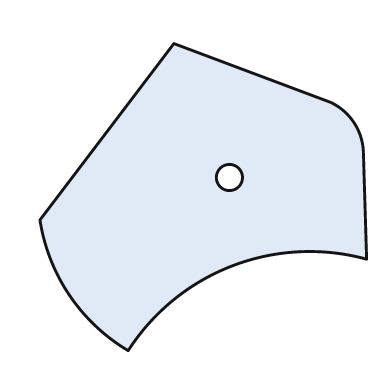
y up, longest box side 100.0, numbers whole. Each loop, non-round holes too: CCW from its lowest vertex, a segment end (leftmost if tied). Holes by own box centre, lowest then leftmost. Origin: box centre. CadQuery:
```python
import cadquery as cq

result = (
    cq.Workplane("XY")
    .moveTo(-23.0, -47.0)
    .threePointArc((9.0, -21.0), (50.0, -19.0))
    .lineTo(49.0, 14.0)
    .threePointArc((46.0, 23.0), (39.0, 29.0))
    .lineTo(-9.0, 47.0)
    .lineTo(-50.0, -7.0)
    .threePointArc((-41.0, -30.0), (-23.0, -47.0))
    .close()
    .moveTo(8.0, 6.0)
    .circle(4.0)
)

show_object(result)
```